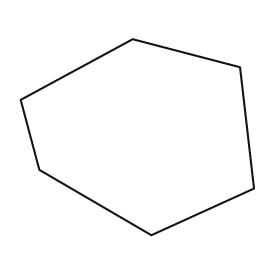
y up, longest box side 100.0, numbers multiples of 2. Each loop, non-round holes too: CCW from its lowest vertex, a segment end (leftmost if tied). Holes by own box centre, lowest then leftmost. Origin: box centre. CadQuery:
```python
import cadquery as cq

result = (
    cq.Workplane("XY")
    .moveTo(6.0, -42.0)
    .lineTo(50.0, -22.0)
    .lineTo(44.0, 30.0)
    .lineTo(-2.0, 42.0)
    .lineTo(-50.0, 16.0)
    .lineTo(-42.0, -14.0)
    .close()
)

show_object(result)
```